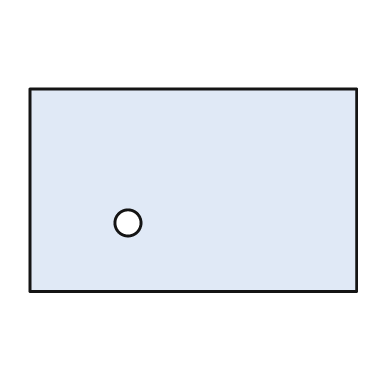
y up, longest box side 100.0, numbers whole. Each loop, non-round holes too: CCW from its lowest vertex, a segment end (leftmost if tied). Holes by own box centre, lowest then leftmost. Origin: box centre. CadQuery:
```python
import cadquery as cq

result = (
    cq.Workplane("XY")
    .moveTo(-50.0, -31.0)
    .lineTo(50.0, -31.0)
    .lineTo(50.0, 31.0)
    .lineTo(-50.0, 31.0)
    .close()
    .moveTo(-20.0, -10.0)
    .circle(4.0)
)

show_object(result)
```